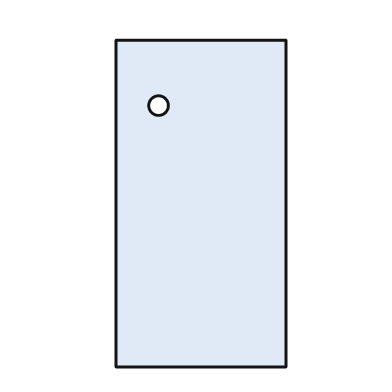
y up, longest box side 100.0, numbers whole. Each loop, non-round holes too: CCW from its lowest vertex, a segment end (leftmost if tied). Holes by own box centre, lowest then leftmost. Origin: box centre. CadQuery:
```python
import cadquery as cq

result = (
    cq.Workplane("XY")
    .moveTo(-26.0, -50.0)
    .lineTo(26.0, -50.0)
    .lineTo(26.0, 50.0)
    .lineTo(-26.0, 50.0)
    .close()
    .moveTo(-13.0, 30.0)
    .circle(3.0)
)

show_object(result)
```